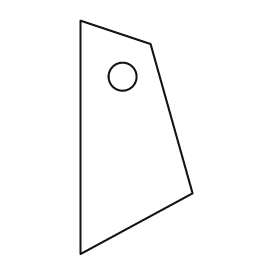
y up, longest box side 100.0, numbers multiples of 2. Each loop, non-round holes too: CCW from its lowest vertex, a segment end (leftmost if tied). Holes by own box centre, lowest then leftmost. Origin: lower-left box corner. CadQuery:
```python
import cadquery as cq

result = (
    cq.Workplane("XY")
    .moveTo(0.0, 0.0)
    .lineTo(48.0, 26.0)
    .lineTo(30.0, 90.0)
    .lineTo(0.0, 100.0)
    .close()
    .moveTo(18.0, 76.0)
    .circle(6.0)
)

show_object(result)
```